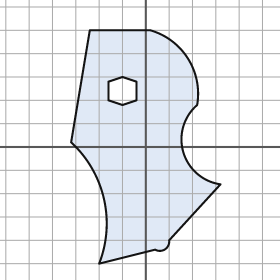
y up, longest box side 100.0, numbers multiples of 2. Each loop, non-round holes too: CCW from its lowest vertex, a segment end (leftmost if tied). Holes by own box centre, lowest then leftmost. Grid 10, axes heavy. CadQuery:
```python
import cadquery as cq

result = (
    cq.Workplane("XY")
    .moveTo(-20.0, -50.0)
    .lineTo(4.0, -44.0)
    .threePointArc((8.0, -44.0), (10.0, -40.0))
    .lineTo(32.0, -16.0)
    .threePointArc((16.0, -2.0), (22.0, 18.0))
    .threePointArc((18.0, 38.0), (2.0, 50.0))
    .lineTo(-24.0, 50.0)
    .lineTo(-32.0, 2.0)
    .threePointArc((-18.0, -22.0), (-20.0, -50.0))
    .close()
    .moveTo(-10.0, 18.0)
    .lineTo(-4.0, 20.0)
    .lineTo(-4.0, 28.0)
    .lineTo(-10.0, 30.0)
    .lineTo(-16.0, 28.0)
    .lineTo(-16.0, 20.0)
    .close()
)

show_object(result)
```